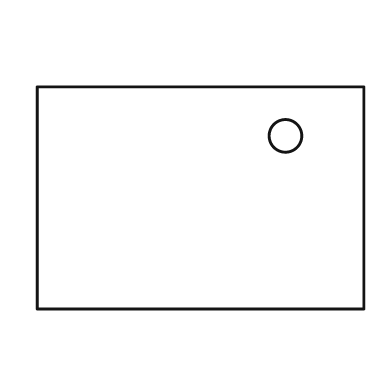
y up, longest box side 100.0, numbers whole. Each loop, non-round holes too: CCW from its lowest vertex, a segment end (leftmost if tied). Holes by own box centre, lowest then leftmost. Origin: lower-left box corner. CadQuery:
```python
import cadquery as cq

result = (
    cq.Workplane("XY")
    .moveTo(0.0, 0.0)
    .lineTo(100.0, 0.0)
    .lineTo(100.0, 68.0)
    .lineTo(0.0, 68.0)
    .close()
    .moveTo(76.0, 53.0)
    .circle(5.0)
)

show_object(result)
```